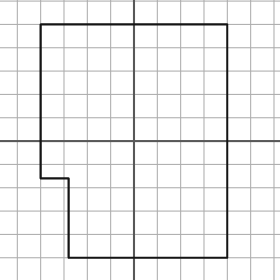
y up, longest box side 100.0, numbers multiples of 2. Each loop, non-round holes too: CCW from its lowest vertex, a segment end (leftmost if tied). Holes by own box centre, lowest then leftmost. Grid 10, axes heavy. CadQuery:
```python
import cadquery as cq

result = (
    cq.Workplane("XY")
    .moveTo(-28.0, -50.0)
    .lineTo(40.0, -50.0)
    .lineTo(40.0, 50.0)
    .lineTo(-40.0, 50.0)
    .lineTo(-40.0, -16.0)
    .lineTo(-28.0, -16.0)
    .close()
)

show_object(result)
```